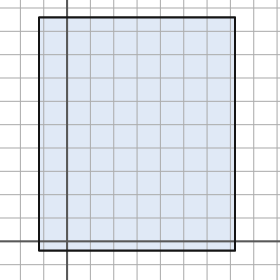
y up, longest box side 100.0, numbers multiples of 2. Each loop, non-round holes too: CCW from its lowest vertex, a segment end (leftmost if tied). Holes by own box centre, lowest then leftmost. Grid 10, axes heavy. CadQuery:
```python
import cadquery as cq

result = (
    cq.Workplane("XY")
    .moveTo(-12.0, -4.0)
    .lineTo(72.0, -4.0)
    .lineTo(72.0, 96.0)
    .lineTo(-12.0, 96.0)
    .close()
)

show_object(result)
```